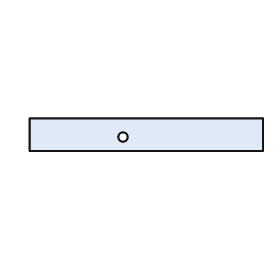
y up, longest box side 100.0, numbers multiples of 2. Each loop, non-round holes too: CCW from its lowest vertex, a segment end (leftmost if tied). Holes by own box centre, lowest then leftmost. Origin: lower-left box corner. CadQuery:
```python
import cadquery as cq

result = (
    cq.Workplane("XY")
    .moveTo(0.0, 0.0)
    .lineTo(100.0, 0.0)
    .lineTo(100.0, 14.0)
    .lineTo(0.0, 14.0)
    .close()
    .moveTo(40.0, 6.0)
    .circle(2.0)
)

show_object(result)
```